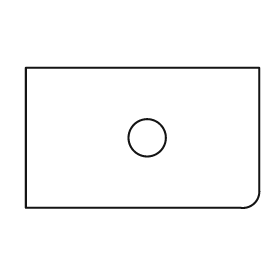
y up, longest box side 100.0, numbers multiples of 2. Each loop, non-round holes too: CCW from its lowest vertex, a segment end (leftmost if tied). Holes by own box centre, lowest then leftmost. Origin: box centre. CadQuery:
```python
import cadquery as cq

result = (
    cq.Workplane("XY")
    .moveTo(-50.0, -30.0)
    .lineTo(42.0, -30.0)
    .threePointArc((48.0, -28.0), (50.0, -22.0))
    .lineTo(50.0, 30.0)
    .lineTo(-50.0, 30.0)
    .close()
    .moveTo(2.0, 0.0)
    .circle(8.0)
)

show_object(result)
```